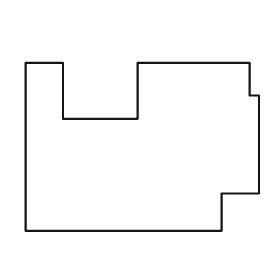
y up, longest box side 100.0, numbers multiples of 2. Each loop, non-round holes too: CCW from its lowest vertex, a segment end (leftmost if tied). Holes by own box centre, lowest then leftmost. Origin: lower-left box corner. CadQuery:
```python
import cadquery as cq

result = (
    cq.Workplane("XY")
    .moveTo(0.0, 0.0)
    .lineTo(84.0, 0.0)
    .lineTo(84.0, 16.0)
    .lineTo(100.0, 16.0)
    .lineTo(100.0, 58.0)
    .lineTo(96.0, 58.0)
    .lineTo(96.0, 72.0)
    .lineTo(48.0, 72.0)
    .lineTo(48.0, 48.0)
    .lineTo(16.0, 48.0)
    .lineTo(16.0, 72.0)
    .lineTo(0.0, 72.0)
    .close()
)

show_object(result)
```